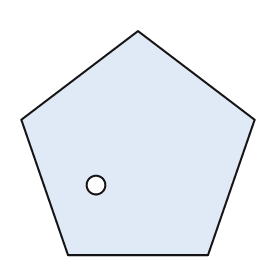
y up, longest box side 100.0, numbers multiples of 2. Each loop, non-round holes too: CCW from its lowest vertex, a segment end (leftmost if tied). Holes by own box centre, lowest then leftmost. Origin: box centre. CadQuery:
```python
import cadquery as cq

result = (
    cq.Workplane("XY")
    .moveTo(-30.0, -48.0)
    .lineTo(30.0, -48.0)
    .lineTo(50.0, 10.0)
    .lineTo(0.0, 48.0)
    .lineTo(-50.0, 10.0)
    .close()
    .moveTo(-18.0, -18.0)
    .circle(4.0)
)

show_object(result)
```